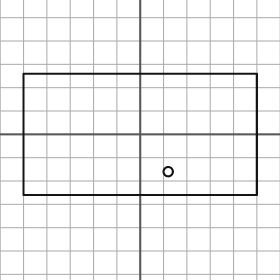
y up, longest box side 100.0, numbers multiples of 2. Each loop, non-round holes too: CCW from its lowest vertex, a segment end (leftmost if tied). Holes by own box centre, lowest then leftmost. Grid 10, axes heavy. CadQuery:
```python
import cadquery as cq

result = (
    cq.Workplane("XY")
    .moveTo(-50.0, -26.0)
    .lineTo(50.0, -26.0)
    .lineTo(50.0, 26.0)
    .lineTo(-50.0, 26.0)
    .close()
    .moveTo(12.0, -16.0)
    .circle(2.0)
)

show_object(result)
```